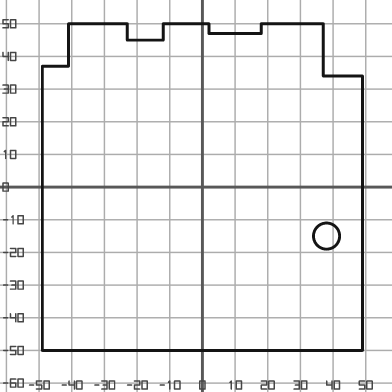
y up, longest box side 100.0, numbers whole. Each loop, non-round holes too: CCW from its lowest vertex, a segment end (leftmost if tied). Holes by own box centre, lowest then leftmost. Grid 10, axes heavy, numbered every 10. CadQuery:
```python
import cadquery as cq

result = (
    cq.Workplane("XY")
    .moveTo(-49.0, -50.0)
    .lineTo(49.0, -50.0)
    .lineTo(49.0, 34.0)
    .lineTo(37.0, 34.0)
    .lineTo(37.0, 50.0)
    .lineTo(18.0, 50.0)
    .lineTo(18.0, 47.0)
    .lineTo(2.0, 47.0)
    .lineTo(2.0, 50.0)
    .lineTo(-12.0, 50.0)
    .lineTo(-12.0, 45.0)
    .lineTo(-23.0, 45.0)
    .lineTo(-23.0, 50.0)
    .lineTo(-41.0, 50.0)
    .lineTo(-41.0, 37.0)
    .lineTo(-49.0, 37.0)
    .close()
    .moveTo(38.0, -15.0)
    .circle(4.0)
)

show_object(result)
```